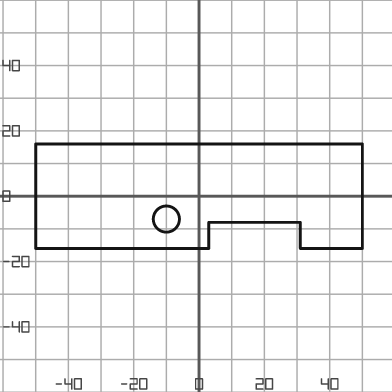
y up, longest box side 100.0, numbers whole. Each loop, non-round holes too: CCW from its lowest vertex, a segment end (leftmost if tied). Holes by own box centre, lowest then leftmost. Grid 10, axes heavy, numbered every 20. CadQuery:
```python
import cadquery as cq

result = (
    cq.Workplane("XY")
    .moveTo(-50.0, -16.0)
    .lineTo(3.0, -16.0)
    .lineTo(3.0, -8.0)
    .lineTo(31.0, -8.0)
    .lineTo(31.0, -16.0)
    .lineTo(50.0, -16.0)
    .lineTo(50.0, 16.0)
    .lineTo(-50.0, 16.0)
    .close()
    .moveTo(-10.0, -7.0)
    .circle(4.0)
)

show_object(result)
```